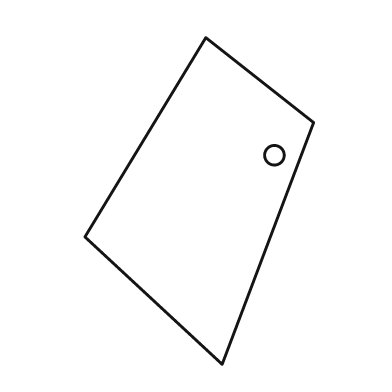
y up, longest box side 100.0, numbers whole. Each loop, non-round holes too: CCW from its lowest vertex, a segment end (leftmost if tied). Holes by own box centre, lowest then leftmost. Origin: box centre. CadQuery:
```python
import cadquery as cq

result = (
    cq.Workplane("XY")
    .moveTo(7.0, -50.0)
    .lineTo(35.0, 24.0)
    .lineTo(2.0, 50.0)
    .lineTo(-35.0, -11.0)
    .close()
    .moveTo(23.0, 14.0)
    .circle(3.0)
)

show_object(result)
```